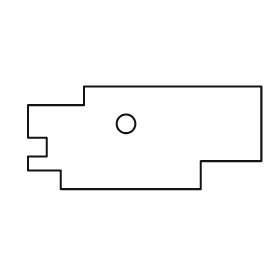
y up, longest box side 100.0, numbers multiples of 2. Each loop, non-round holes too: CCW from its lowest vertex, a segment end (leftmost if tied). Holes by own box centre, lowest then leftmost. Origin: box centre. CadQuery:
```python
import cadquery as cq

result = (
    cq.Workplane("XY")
    .moveTo(-36.0, -22.0)
    .lineTo(24.0, -22.0)
    .lineTo(24.0, -10.0)
    .lineTo(50.0, -10.0)
    .lineTo(50.0, 22.0)
    .lineTo(-26.0, 22.0)
    .lineTo(-26.0, 14.0)
    .lineTo(-50.0, 14.0)
    .lineTo(-50.0, 0.0)
    .lineTo(-42.0, 0.0)
    .lineTo(-42.0, -8.0)
    .lineTo(-50.0, -8.0)
    .lineTo(-50.0, -14.0)
    .lineTo(-36.0, -14.0)
    .close()
    .moveTo(-8.0, 6.0)
    .circle(4.0)
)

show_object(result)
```